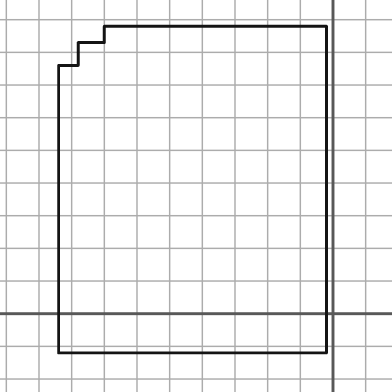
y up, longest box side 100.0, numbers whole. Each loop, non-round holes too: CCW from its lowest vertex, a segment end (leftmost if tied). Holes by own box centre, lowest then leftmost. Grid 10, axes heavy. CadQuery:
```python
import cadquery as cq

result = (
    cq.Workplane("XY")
    .moveTo(-84.0, -12.0)
    .lineTo(-2.0, -12.0)
    .lineTo(-2.0, 88.0)
    .lineTo(-70.0, 88.0)
    .lineTo(-70.0, 83.0)
    .lineTo(-78.0, 83.0)
    .lineTo(-78.0, 76.0)
    .lineTo(-84.0, 76.0)
    .close()
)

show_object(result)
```